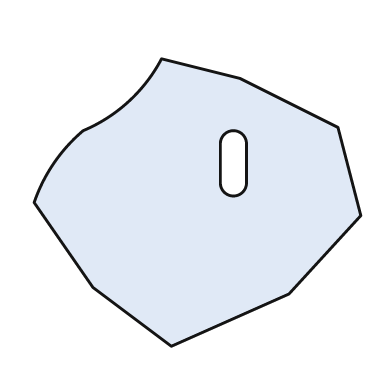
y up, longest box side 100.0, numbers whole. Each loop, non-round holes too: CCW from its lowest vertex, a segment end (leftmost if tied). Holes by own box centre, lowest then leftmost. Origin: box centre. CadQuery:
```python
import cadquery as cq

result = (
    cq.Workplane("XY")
    .moveTo(-8.0, -44.0)
    .lineTo(28.0, -28.0)
    .lineTo(50.0, -4.0)
    .lineTo(43.0, 23.0)
    .lineTo(13.0, 38.0)
    .lineTo(-11.0, 44.0)
    .threePointArc((-21.0, 31.0), (-35.0, 22.0))
    .threePointArc((-44.0, 12.0), (-50.0, 0.0))
    .lineTo(-32.0, -26.0)
    .close()
    .moveTo(7.0, 6.0)
    .threePointArc((11.0, 2.0), (15.0, 6.0))
    .lineTo(15.0, 18.0)
    .threePointArc((11.0, 22.0), (7.0, 18.0))
    .close()
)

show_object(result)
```